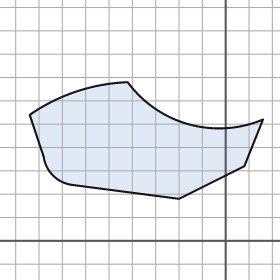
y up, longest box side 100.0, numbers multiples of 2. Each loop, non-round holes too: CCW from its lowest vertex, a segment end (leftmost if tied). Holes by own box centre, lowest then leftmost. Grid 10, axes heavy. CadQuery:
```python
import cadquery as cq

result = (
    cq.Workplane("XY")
    .moveTo(-20.0, 18.0)
    .lineTo(8.0, 32.0)
    .lineTo(16.0, 52.0)
    .threePointArc((-16.0, 50.0), (-42.0, 68.0))
    .threePointArc((-64.0, 64.0), (-84.0, 54.0))
    .lineTo(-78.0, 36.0)
    .threePointArc((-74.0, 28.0), (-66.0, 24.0))
    .close()
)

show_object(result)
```